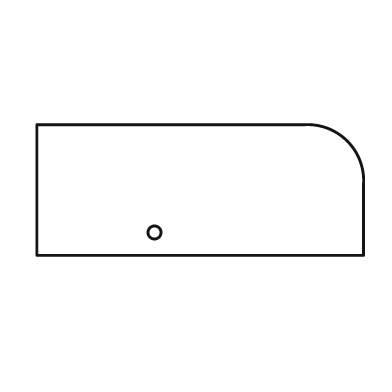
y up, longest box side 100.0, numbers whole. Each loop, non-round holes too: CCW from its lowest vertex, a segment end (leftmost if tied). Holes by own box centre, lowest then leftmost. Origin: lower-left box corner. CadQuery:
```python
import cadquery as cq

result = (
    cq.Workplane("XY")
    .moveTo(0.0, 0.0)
    .lineTo(100.0, 0.0)
    .lineTo(100.0, 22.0)
    .threePointArc((95.0, 35.0), (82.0, 40.0))
    .lineTo(0.0, 40.0)
    .close()
    .moveTo(36.0, 7.0)
    .circle(2.0)
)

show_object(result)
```